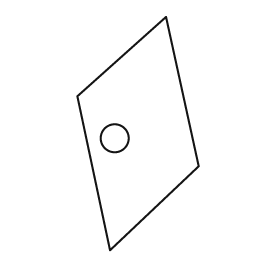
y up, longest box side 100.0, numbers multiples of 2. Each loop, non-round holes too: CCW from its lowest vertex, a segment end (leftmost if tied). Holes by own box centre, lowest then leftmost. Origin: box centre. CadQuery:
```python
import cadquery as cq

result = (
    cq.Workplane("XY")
    .moveTo(-12.0, -50.0)
    .lineTo(26.0, -14.0)
    .lineTo(12.0, 50.0)
    .lineTo(-26.0, 16.0)
    .close()
    .moveTo(-10.0, -2.0)
    .circle(6.0)
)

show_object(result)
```